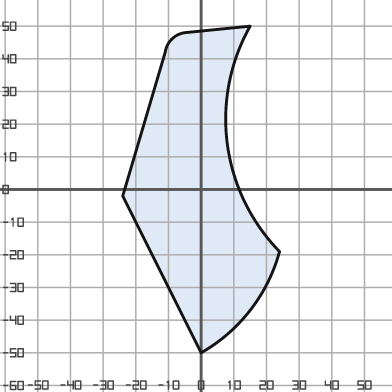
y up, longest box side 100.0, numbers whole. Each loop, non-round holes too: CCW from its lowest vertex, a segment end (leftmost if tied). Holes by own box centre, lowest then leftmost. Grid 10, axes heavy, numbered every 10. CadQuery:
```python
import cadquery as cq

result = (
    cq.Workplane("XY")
    .moveTo(0.0, -50.0)
    .threePointArc((15.0, -37.0), (24.0, -19.0))
    .threePointArc((8.0, 14.0), (15.0, 50.0))
    .lineTo(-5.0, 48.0)
    .threePointArc((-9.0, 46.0), (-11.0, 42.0))
    .lineTo(-24.0, -2.0)
    .close()
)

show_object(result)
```